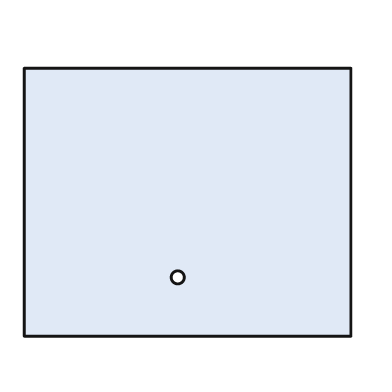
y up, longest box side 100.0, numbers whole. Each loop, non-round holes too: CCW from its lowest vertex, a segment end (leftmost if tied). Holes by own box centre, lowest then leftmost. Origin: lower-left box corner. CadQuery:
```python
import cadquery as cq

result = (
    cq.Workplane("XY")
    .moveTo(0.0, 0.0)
    .lineTo(100.0, 0.0)
    .lineTo(100.0, 82.0)
    .lineTo(0.0, 82.0)
    .close()
    .moveTo(47.0, 18.0)
    .circle(2.0)
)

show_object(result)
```